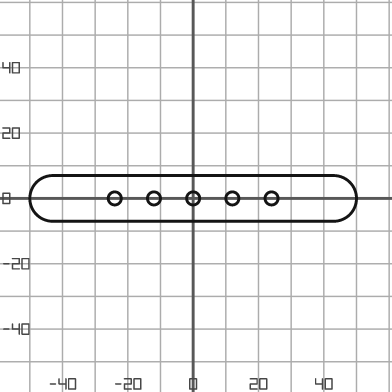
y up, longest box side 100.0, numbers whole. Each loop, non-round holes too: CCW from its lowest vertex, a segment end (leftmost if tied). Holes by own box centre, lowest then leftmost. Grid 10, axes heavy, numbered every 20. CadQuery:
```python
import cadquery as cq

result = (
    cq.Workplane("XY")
    .moveTo(-43.0, -7.0)
    .lineTo(43.0, -7.0)
    .threePointArc((50.0, 0.0), (43.0, 7.0))
    .lineTo(-43.0, 7.0)
    .threePointArc((-50.0, 0.0), (-43.0, -7.0))
    .close()
    .moveTo(-24.0, 0.0)
    .circle(2.0)
    .moveTo(-12.0, 0.0)
    .circle(2.0)
    .moveTo(0.0, 0.0)
    .circle(2.0)
    .moveTo(12.0, 0.0)
    .circle(2.0)
    .moveTo(24.0, 0.0)
    .circle(2.0)
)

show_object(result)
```